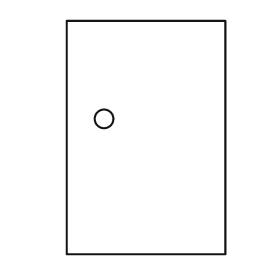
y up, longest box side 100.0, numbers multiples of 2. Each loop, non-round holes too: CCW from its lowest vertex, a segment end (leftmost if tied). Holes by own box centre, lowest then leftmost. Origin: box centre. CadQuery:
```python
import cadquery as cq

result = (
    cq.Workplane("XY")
    .moveTo(-34.0, -50.0)
    .lineTo(34.0, -50.0)
    .lineTo(34.0, 50.0)
    .lineTo(-34.0, 50.0)
    .close()
    .moveTo(-18.0, 8.0)
    .circle(4.0)
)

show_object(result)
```